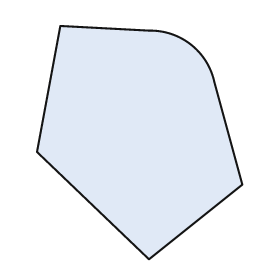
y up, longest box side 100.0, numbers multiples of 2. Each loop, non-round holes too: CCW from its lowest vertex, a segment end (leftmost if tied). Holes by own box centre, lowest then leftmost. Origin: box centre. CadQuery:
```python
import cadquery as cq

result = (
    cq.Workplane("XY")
    .moveTo(4.0, -50.0)
    .lineTo(44.0, -18.0)
    .lineTo(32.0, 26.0)
    .threePointArc((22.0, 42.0), (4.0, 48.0))
    .lineTo(-34.0, 50.0)
    .lineTo(-44.0, -4.0)
    .close()
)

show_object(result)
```